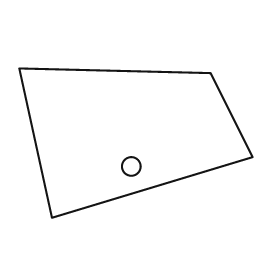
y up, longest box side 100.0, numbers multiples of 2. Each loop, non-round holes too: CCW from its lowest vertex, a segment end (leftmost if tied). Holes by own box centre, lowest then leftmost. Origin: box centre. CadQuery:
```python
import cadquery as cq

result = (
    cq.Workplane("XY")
    .moveTo(-36.0, -32.0)
    .lineTo(50.0, -6.0)
    .lineTo(32.0, 30.0)
    .lineTo(-50.0, 32.0)
    .close()
    .moveTo(-2.0, -10.0)
    .circle(4.0)
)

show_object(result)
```